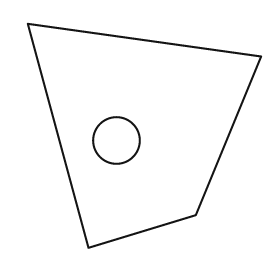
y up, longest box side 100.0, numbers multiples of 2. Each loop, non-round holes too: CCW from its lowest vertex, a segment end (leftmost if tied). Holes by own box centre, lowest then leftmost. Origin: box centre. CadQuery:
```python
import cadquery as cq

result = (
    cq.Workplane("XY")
    .moveTo(-24.0, -48.0)
    .lineTo(22.0, -34.0)
    .lineTo(50.0, 34.0)
    .lineTo(-50.0, 48.0)
    .close()
    .moveTo(-12.0, -2.0)
    .circle(10.0)
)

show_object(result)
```